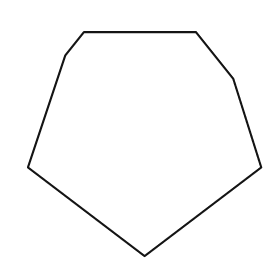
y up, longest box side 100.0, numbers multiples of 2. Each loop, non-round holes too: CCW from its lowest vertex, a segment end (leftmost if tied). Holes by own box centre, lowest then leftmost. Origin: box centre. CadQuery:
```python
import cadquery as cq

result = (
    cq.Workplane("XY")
    .moveTo(0.0, -48.0)
    .lineTo(50.0, -10.0)
    .lineTo(38.0, 28.0)
    .lineTo(22.0, 48.0)
    .lineTo(-26.0, 48.0)
    .lineTo(-34.0, 38.0)
    .lineTo(-50.0, -10.0)
    .close()
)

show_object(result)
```